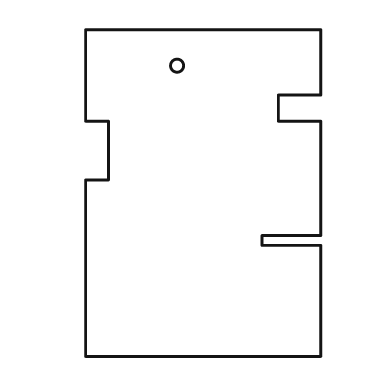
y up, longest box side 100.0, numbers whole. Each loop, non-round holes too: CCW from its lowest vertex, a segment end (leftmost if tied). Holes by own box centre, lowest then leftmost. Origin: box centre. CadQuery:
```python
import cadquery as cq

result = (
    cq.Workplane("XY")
    .moveTo(-36.0, -50.0)
    .lineTo(36.0, -50.0)
    .lineTo(36.0, -16.0)
    .lineTo(18.0, -16.0)
    .lineTo(18.0, -13.0)
    .lineTo(36.0, -13.0)
    .lineTo(36.0, 22.0)
    .lineTo(23.0, 22.0)
    .lineTo(23.0, 30.0)
    .lineTo(36.0, 30.0)
    .lineTo(36.0, 50.0)
    .lineTo(-36.0, 50.0)
    .lineTo(-36.0, 22.0)
    .lineTo(-29.0, 22.0)
    .lineTo(-29.0, 4.0)
    .lineTo(-36.0, 4.0)
    .close()
    .moveTo(-8.0, 39.0)
    .circle(2.0)
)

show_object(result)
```